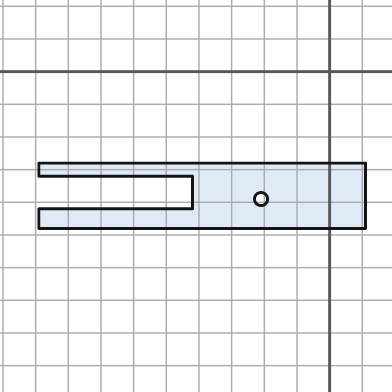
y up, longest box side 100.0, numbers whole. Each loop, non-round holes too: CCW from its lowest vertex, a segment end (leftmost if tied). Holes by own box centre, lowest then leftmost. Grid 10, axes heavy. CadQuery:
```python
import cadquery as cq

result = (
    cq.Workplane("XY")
    .moveTo(-89.0, -48.0)
    .lineTo(11.0, -48.0)
    .lineTo(11.0, -28.0)
    .lineTo(-89.0, -28.0)
    .lineTo(-89.0, -32.0)
    .lineTo(-42.0, -32.0)
    .lineTo(-42.0, -42.0)
    .lineTo(-89.0, -42.0)
    .close()
    .moveTo(-21.0, -39.0)
    .circle(2.0)
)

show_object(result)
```